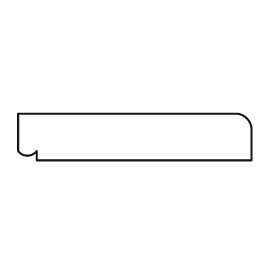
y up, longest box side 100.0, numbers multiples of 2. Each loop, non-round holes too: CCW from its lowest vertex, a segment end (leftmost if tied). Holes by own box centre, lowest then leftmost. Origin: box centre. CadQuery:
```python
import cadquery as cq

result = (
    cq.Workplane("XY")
    .moveTo(-42.0, -10.0)
    .lineTo(50.0, -10.0)
    .lineTo(50.0, 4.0)
    .threePointArc((48.0, 8.0), (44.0, 10.0))
    .lineTo(-50.0, 10.0)
    .lineTo(-50.0, -6.0)
    .threePointArc((-46.0, -8.0), (-42.0, -6.0))
    .close()
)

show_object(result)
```